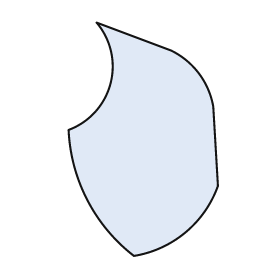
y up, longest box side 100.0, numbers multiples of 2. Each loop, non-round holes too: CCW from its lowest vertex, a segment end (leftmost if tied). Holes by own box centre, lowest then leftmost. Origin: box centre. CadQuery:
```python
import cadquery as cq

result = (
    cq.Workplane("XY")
    .moveTo(-4.0, -50.0)
    .threePointArc((18.0, -40.0), (32.0, -20.0))
    .lineTo(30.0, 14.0)
    .threePointArc((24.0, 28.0), (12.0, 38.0))
    .lineTo(-20.0, 50.0)
    .threePointArc((-14.0, 24.0), (-32.0, 4.0))
    .threePointArc((-24.0, -26.0), (-4.0, -50.0))
    .close()
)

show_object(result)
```